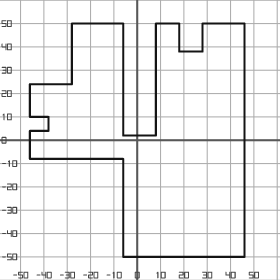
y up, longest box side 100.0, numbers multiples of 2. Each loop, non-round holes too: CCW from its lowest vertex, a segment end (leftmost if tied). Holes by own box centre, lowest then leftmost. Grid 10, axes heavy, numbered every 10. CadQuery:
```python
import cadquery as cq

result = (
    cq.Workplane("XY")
    .moveTo(-6.0, -50.0)
    .lineTo(46.0, -50.0)
    .lineTo(46.0, 50.0)
    .lineTo(28.0, 50.0)
    .lineTo(28.0, 38.0)
    .lineTo(18.0, 38.0)
    .lineTo(18.0, 50.0)
    .lineTo(8.0, 50.0)
    .lineTo(8.0, 2.0)
    .lineTo(-6.0, 2.0)
    .lineTo(-6.0, 50.0)
    .lineTo(-28.0, 50.0)
    .lineTo(-28.0, 24.0)
    .lineTo(-46.0, 24.0)
    .lineTo(-46.0, 10.0)
    .lineTo(-38.0, 10.0)
    .lineTo(-38.0, 4.0)
    .lineTo(-46.0, 4.0)
    .lineTo(-46.0, -8.0)
    .lineTo(-6.0, -8.0)
    .close()
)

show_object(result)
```